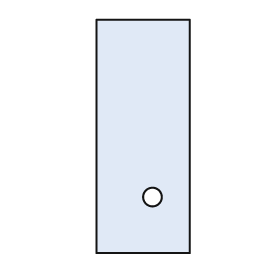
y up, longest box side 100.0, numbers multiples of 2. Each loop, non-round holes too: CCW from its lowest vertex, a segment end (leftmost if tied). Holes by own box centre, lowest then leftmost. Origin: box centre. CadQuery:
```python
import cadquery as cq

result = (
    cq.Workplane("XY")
    .moveTo(-20.0, -50.0)
    .lineTo(20.0, -50.0)
    .lineTo(20.0, 50.0)
    .lineTo(-20.0, 50.0)
    .close()
    .moveTo(4.0, -26.0)
    .circle(4.0)
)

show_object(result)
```